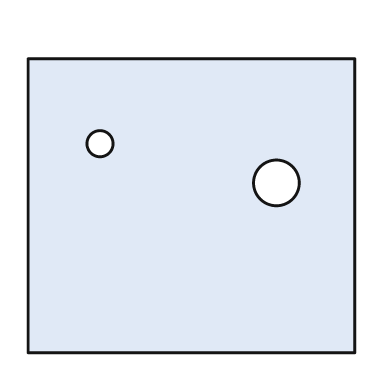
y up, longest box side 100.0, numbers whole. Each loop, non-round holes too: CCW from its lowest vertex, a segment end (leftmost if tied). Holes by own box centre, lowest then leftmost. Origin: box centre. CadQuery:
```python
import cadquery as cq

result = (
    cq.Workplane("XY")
    .moveTo(-50.0, -45.0)
    .lineTo(50.0, -45.0)
    .lineTo(50.0, 45.0)
    .lineTo(-50.0, 45.0)
    .close()
    .moveTo(26.0, 7.0)
    .circle(7.0)
    .moveTo(-28.0, 19.0)
    .circle(4.0)
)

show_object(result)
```